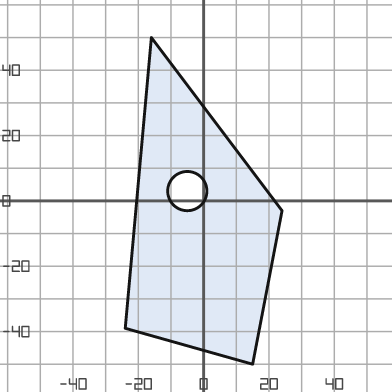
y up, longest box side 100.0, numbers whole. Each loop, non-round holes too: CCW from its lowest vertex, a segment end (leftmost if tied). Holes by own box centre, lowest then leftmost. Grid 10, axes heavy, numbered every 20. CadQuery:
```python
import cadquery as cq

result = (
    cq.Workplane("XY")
    .moveTo(15.0, -50.0)
    .lineTo(24.0, -3.0)
    .lineTo(-16.0, 50.0)
    .lineTo(-24.0, -39.0)
    .close()
    .moveTo(-5.0, 3.0)
    .circle(6.0)
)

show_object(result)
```